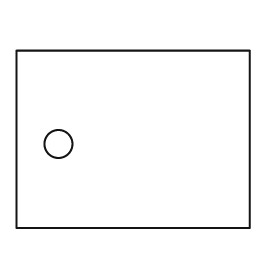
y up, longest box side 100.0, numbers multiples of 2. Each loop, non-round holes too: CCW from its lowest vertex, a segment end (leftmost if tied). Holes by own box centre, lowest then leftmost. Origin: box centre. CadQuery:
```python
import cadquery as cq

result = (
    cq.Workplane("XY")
    .moveTo(-50.0, -38.0)
    .lineTo(50.0, -38.0)
    .lineTo(50.0, 38.0)
    .lineTo(-50.0, 38.0)
    .close()
    .moveTo(-32.0, -2.0)
    .circle(6.0)
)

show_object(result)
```